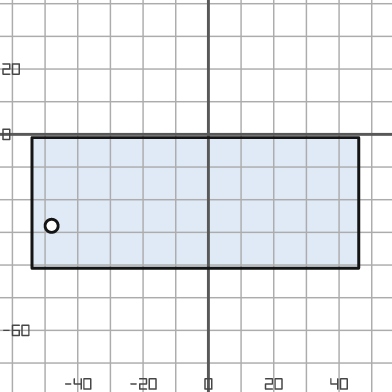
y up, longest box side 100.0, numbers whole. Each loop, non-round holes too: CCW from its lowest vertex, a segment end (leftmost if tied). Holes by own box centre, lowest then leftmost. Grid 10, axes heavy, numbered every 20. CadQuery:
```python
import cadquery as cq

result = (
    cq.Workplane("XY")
    .moveTo(-54.0, -41.0)
    .lineTo(46.0, -41.0)
    .lineTo(46.0, -1.0)
    .lineTo(-54.0, -1.0)
    .close()
    .moveTo(-48.0, -28.0)
    .circle(2.0)
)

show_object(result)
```